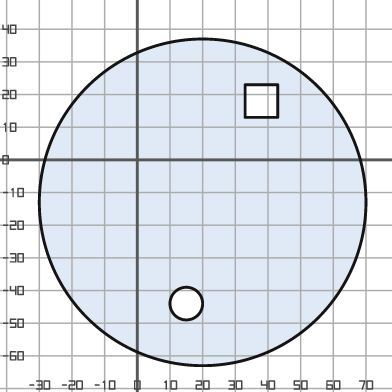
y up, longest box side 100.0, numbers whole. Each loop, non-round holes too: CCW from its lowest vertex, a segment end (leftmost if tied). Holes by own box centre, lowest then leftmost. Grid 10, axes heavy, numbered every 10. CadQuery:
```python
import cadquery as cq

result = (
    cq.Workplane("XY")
    .moveTo(20.0, -13.0)
    .circle(50.0)
    .moveTo(15.0, -44.0)
    .circle(5.0)
    .moveTo(33.0, 13.0)
    .lineTo(43.0, 13.0)
    .lineTo(43.0, 23.0)
    .lineTo(33.0, 23.0)
    .close()
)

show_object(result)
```